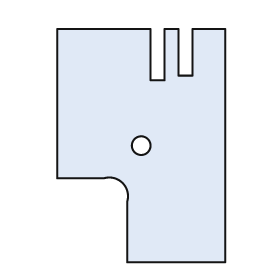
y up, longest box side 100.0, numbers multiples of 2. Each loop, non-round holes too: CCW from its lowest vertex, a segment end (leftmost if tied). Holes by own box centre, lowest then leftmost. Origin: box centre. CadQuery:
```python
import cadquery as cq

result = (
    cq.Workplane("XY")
    .moveTo(-6.0, -50.0)
    .lineTo(36.0, -50.0)
    .lineTo(36.0, 50.0)
    .lineTo(22.0, 50.0)
    .lineTo(22.0, 30.0)
    .lineTo(16.0, 30.0)
    .lineTo(16.0, 50.0)
    .lineTo(10.0, 50.0)
    .lineTo(10.0, 28.0)
    .lineTo(4.0, 28.0)
    .lineTo(4.0, 50.0)
    .lineTo(-36.0, 50.0)
    .lineTo(-36.0, -14.0)
    .lineTo(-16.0, -14.0)
    .threePointArc((-8.0, -16.0), (-6.0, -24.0))
    .close()
    .moveTo(0.0, 0.0)
    .circle(4.0)
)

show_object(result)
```